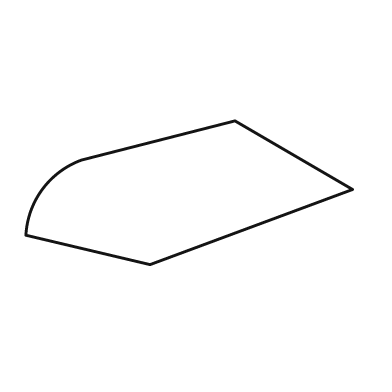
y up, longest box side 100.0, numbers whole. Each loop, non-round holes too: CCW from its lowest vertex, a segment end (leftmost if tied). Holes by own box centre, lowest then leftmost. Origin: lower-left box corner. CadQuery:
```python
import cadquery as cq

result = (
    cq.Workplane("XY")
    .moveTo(38.0, 0.0)
    .lineTo(100.0, 23.0)
    .lineTo(64.0, 44.0)
    .lineTo(17.0, 32.0)
    .threePointArc((5.0, 23.0), (0.0, 9.0))
    .close()
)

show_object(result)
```